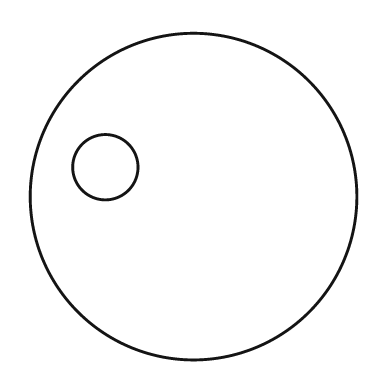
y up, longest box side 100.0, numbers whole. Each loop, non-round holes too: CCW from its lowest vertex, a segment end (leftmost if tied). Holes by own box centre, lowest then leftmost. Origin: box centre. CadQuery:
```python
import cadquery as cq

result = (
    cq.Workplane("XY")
    .moveTo(0.0, 0.0)
    .circle(50.0)
    .moveTo(-27.0, 9.0)
    .circle(10.0)
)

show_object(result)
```